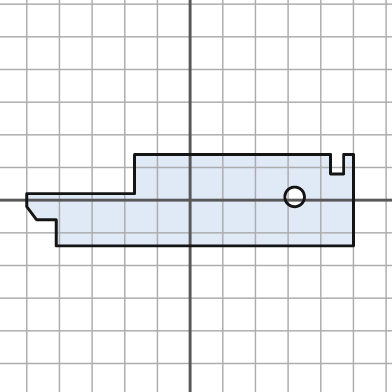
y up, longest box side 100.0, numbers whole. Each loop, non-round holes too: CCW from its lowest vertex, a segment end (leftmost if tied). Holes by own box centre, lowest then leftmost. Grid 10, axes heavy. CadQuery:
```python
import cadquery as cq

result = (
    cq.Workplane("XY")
    .moveTo(-41.0, -14.0)
    .lineTo(50.0, -14.0)
    .lineTo(50.0, 14.0)
    .lineTo(47.0, 14.0)
    .lineTo(47.0, 8.0)
    .lineTo(43.0, 8.0)
    .lineTo(43.0, 14.0)
    .lineTo(-17.0, 14.0)
    .lineTo(-17.0, 2.0)
    .lineTo(-50.0, 2.0)
    .lineTo(-50.0, -2.0)
    .lineTo(-47.0, -6.0)
    .lineTo(-41.0, -6.0)
    .close()
    .moveTo(32.0, 1.0)
    .circle(3.0)
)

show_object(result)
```